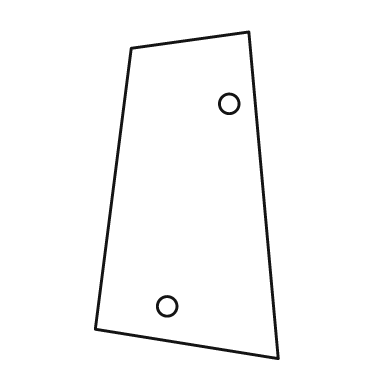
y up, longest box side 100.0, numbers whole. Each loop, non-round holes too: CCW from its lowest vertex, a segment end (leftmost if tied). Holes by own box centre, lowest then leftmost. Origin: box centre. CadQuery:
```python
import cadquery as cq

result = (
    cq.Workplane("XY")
    .moveTo(28.0, -50.0)
    .lineTo(19.0, 50.0)
    .lineTo(-17.0, 45.0)
    .lineTo(-28.0, -41.0)
    .close()
    .moveTo(-6.0, -34.0)
    .circle(3.0)
    .moveTo(13.0, 28.0)
    .circle(3.0)
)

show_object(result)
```